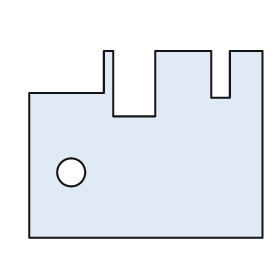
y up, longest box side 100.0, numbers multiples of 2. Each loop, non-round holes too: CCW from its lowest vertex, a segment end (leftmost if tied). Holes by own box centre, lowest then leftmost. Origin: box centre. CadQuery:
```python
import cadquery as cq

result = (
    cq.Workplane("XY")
    .moveTo(-50.0, -40.0)
    .lineTo(50.0, -40.0)
    .lineTo(50.0, 40.0)
    .lineTo(36.0, 40.0)
    .lineTo(36.0, 20.0)
    .lineTo(28.0, 20.0)
    .lineTo(28.0, 40.0)
    .lineTo(4.0, 40.0)
    .lineTo(4.0, 12.0)
    .lineTo(-14.0, 12.0)
    .lineTo(-14.0, 40.0)
    .lineTo(-18.0, 40.0)
    .lineTo(-18.0, 22.0)
    .lineTo(-50.0, 22.0)
    .close()
    .moveTo(-32.0, -12.0)
    .circle(6.0)
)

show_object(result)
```